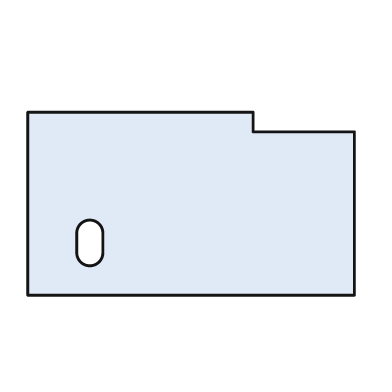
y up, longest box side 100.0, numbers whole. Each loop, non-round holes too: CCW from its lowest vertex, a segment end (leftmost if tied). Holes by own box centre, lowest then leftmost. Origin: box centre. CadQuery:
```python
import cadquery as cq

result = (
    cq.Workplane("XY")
    .moveTo(-50.0, -28.0)
    .lineTo(50.0, -28.0)
    .lineTo(50.0, 22.0)
    .lineTo(19.0, 22.0)
    .lineTo(19.0, 28.0)
    .lineTo(-50.0, 28.0)
    .close()
    .moveTo(-35.0, -15.0)
    .threePointArc((-31.0, -19.0), (-27.0, -15.0))
    .lineTo(-27.0, -9.0)
    .threePointArc((-31.0, -5.0), (-35.0, -9.0))
    .close()
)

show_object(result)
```